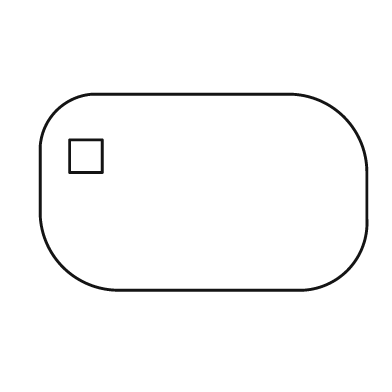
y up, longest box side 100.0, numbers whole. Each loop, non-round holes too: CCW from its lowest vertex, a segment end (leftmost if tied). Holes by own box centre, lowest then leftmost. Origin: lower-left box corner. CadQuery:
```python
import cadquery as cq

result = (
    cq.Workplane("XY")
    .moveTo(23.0, 0.0)
    .lineTo(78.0, 0.0)
    .threePointArc((94.0, 6.0), (100.0, 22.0))
    .lineTo(100.0, 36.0)
    .threePointArc((93.0, 53.0), (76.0, 60.0))
    .lineTo(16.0, 60.0)
    .threePointArc((5.0, 55.0), (0.0, 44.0))
    .lineTo(0.0, 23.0)
    .threePointArc((7.0, 7.0), (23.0, 0.0))
    .close()
    .moveTo(9.0, 36.0)
    .lineTo(19.0, 36.0)
    .lineTo(19.0, 46.0)
    .lineTo(9.0, 46.0)
    .close()
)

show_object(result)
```